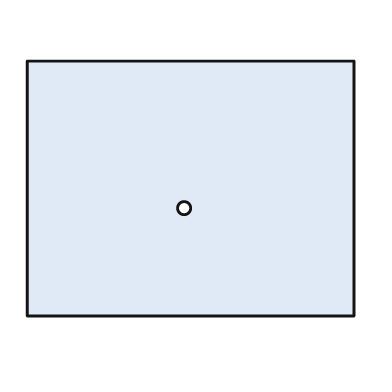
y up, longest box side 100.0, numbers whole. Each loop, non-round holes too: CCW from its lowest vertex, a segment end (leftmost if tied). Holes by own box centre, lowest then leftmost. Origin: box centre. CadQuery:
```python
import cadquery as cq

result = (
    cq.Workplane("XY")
    .moveTo(-50.0, -39.0)
    .lineTo(50.0, -39.0)
    .lineTo(50.0, 39.0)
    .lineTo(-50.0, 39.0)
    .close()
    .moveTo(-2.0, -6.0)
    .circle(2.0)
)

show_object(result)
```